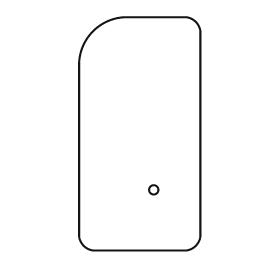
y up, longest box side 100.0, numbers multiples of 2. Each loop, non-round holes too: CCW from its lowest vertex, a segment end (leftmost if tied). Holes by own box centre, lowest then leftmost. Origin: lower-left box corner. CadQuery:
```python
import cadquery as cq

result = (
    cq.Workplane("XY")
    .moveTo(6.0, 0.0)
    .lineTo(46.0, 0.0)
    .threePointArc((50.0, 2.0), (52.0, 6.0))
    .lineTo(52.0, 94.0)
    .threePointArc((50.0, 98.0), (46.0, 100.0))
    .lineTo(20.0, 100.0)
    .threePointArc((6.0, 94.0), (0.0, 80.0))
    .lineTo(0.0, 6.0)
    .threePointArc((2.0, 2.0), (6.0, 0.0))
    .close()
    .moveTo(32.0, 26.0)
    .circle(2.0)
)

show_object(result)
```